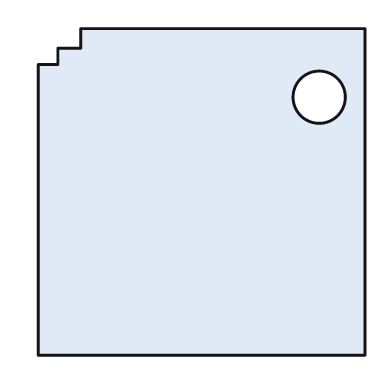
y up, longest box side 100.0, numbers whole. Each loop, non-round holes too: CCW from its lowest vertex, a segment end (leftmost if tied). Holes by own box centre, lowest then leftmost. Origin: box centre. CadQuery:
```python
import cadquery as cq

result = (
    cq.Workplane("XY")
    .moveTo(-50.0, -50.0)
    .lineTo(50.0, -50.0)
    .lineTo(50.0, 50.0)
    .lineTo(-37.0, 50.0)
    .lineTo(-37.0, 44.0)
    .lineTo(-44.0, 44.0)
    .lineTo(-44.0, 39.0)
    .lineTo(-50.0, 39.0)
    .close()
    .moveTo(36.0, 29.0)
    .circle(8.0)
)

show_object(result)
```